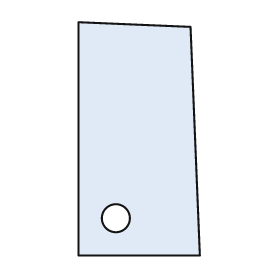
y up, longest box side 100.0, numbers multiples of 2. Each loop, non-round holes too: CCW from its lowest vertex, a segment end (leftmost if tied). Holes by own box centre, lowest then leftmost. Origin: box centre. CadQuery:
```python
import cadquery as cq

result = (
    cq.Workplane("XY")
    .moveTo(-26.0, -50.0)
    .lineTo(26.0, -50.0)
    .lineTo(22.0, 48.0)
    .lineTo(-26.0, 50.0)
    .close()
    .moveTo(-10.0, -34.0)
    .circle(6.0)
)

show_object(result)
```